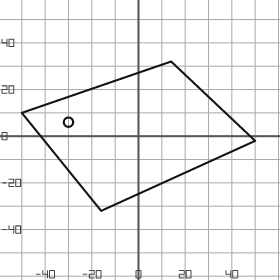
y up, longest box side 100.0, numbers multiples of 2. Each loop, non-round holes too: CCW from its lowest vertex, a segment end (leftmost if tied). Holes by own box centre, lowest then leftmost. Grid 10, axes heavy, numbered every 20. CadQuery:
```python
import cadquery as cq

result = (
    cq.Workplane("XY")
    .moveTo(-16.0, -32.0)
    .lineTo(50.0, -2.0)
    .lineTo(14.0, 32.0)
    .lineTo(-50.0, 10.0)
    .close()
    .moveTo(-30.0, 6.0)
    .circle(2.0)
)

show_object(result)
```